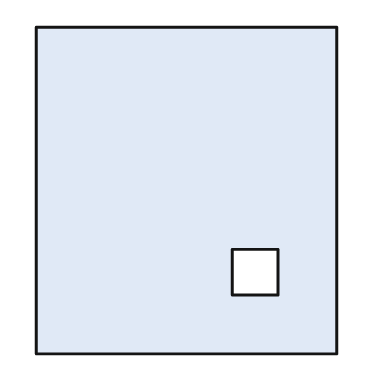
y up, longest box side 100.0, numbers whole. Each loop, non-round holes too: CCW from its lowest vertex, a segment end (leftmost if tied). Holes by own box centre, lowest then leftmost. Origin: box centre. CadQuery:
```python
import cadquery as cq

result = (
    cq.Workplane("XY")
    .moveTo(-46.0, -50.0)
    .lineTo(46.0, -50.0)
    .lineTo(46.0, 50.0)
    .lineTo(-46.0, 50.0)
    .close()
    .moveTo(14.0, -32.0)
    .lineTo(28.0, -32.0)
    .lineTo(28.0, -18.0)
    .lineTo(14.0, -18.0)
    .close()
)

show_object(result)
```